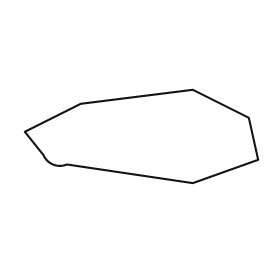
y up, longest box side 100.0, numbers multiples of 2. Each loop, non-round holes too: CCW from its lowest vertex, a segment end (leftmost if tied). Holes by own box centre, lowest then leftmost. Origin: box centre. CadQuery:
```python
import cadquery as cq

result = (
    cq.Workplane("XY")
    .moveTo(22.0, -20.0)
    .lineTo(50.0, -10.0)
    .lineTo(46.0, 8.0)
    .lineTo(22.0, 20.0)
    .lineTo(-26.0, 14.0)
    .lineTo(-50.0, 2.0)
    .lineTo(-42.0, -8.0)
    .threePointArc((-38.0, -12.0), (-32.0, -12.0))
    .close()
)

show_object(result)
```